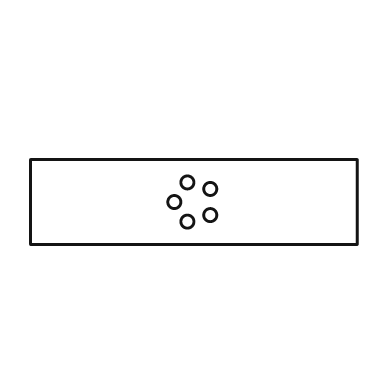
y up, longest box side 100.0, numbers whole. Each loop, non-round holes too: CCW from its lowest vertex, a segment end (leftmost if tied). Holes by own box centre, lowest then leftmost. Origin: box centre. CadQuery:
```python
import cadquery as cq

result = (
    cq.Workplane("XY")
    .moveTo(-50.0, -13.0)
    .lineTo(50.0, -13.0)
    .lineTo(50.0, 13.0)
    .lineTo(-50.0, 13.0)
    .close()
    .moveTo(-2.0, -6.0)
    .circle(2.0)
    .moveTo(5.0, -4.0)
    .circle(2.0)
    .moveTo(-6.0, 0.0)
    .circle(2.0)
    .moveTo(5.0, 4.0)
    .circle(2.0)
    .moveTo(-2.0, 6.0)
    .circle(2.0)
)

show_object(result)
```